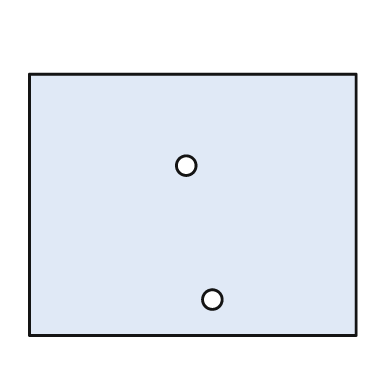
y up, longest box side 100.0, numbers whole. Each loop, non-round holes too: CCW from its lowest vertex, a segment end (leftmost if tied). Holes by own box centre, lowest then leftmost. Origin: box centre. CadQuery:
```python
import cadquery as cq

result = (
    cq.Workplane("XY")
    .moveTo(-50.0, -40.0)
    .lineTo(50.0, -40.0)
    .lineTo(50.0, 40.0)
    .lineTo(-50.0, 40.0)
    .close()
    .moveTo(6.0, -29.0)
    .circle(3.0)
    .moveTo(-2.0, 12.0)
    .circle(3.0)
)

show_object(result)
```